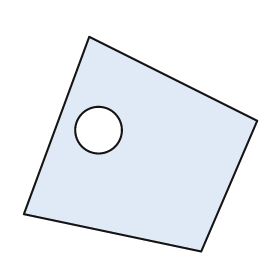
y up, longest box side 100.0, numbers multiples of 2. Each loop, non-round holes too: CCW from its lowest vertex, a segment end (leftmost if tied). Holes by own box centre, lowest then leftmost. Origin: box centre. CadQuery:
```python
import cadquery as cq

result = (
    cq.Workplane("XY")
    .moveTo(26.0, -46.0)
    .lineTo(50.0, 10.0)
    .lineTo(-22.0, 46.0)
    .lineTo(-50.0, -30.0)
    .close()
    .moveTo(-18.0, 6.0)
    .circle(10.0)
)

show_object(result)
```